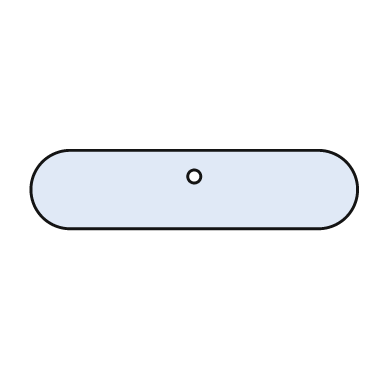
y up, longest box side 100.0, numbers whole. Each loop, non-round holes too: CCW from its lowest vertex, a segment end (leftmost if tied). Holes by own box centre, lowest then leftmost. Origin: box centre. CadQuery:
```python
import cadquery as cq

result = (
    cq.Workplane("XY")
    .moveTo(-38.0, -12.0)
    .lineTo(38.0, -12.0)
    .threePointArc((50.0, 0.0), (38.0, 12.0))
    .lineTo(-38.0, 12.0)
    .threePointArc((-50.0, 0.0), (-38.0, -12.0))
    .close()
    .moveTo(0.0, 4.0)
    .circle(2.0)
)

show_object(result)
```